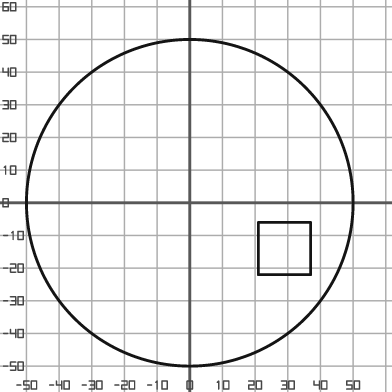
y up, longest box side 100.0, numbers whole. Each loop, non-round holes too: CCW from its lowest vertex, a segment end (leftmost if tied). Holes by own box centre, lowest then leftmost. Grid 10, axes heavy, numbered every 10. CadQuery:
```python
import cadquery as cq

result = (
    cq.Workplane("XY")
    .moveTo(0.0, 0.0)
    .circle(50.0)
    .moveTo(21.0, -22.0)
    .lineTo(37.0, -22.0)
    .lineTo(37.0, -6.0)
    .lineTo(21.0, -6.0)
    .close()
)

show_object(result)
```